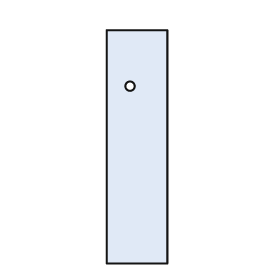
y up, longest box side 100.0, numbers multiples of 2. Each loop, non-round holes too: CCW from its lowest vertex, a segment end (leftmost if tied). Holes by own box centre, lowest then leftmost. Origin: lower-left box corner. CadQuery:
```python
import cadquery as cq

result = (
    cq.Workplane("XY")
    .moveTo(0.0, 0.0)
    .lineTo(26.0, 0.0)
    .lineTo(26.0, 100.0)
    .lineTo(0.0, 100.0)
    .close()
    .moveTo(10.0, 76.0)
    .circle(2.0)
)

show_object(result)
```